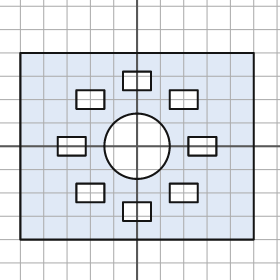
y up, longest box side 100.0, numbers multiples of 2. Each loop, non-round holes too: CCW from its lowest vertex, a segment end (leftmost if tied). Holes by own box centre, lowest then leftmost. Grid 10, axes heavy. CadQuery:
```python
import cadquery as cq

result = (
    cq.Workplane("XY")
    .moveTo(-50.0, -40.0)
    .lineTo(50.0, -40.0)
    .lineTo(50.0, 40.0)
    .lineTo(-50.0, 40.0)
    .close()
    .moveTo(-6.0, -32.0)
    .lineTo(6.0, -32.0)
    .lineTo(6.0, -24.0)
    .lineTo(-6.0, -24.0)
    .close()
    .moveTo(-26.0, -24.0)
    .lineTo(-14.0, -24.0)
    .lineTo(-14.0, -16.0)
    .lineTo(-26.0, -16.0)
    .close()
    .moveTo(14.0, -24.0)
    .lineTo(26.0, -24.0)
    .lineTo(26.0, -16.0)
    .lineTo(14.0, -16.0)
    .close()
    .moveTo(-34.0, -4.0)
    .lineTo(-22.0, -4.0)
    .lineTo(-22.0, 4.0)
    .lineTo(-34.0, 4.0)
    .close()
    .moveTo(0.0, 0.0)
    .circle(14.0)
    .moveTo(22.0, -4.0)
    .lineTo(34.0, -4.0)
    .lineTo(34.0, 4.0)
    .lineTo(22.0, 4.0)
    .close()
    .moveTo(-26.0, 16.0)
    .lineTo(-14.0, 16.0)
    .lineTo(-14.0, 24.0)
    .lineTo(-26.0, 24.0)
    .close()
    .moveTo(14.0, 16.0)
    .lineTo(26.0, 16.0)
    .lineTo(26.0, 24.0)
    .lineTo(14.0, 24.0)
    .close()
    .moveTo(-6.0, 24.0)
    .lineTo(6.0, 24.0)
    .lineTo(6.0, 32.0)
    .lineTo(-6.0, 32.0)
    .close()
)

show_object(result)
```